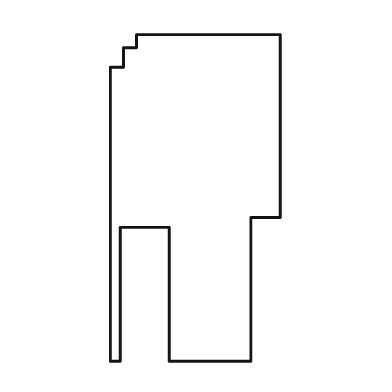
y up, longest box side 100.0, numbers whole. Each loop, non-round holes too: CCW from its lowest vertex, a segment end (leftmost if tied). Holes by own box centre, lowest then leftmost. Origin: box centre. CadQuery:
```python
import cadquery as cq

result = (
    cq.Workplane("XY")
    .moveTo(-26.0, -50.0)
    .lineTo(-23.0, -50.0)
    .lineTo(-23.0, -9.0)
    .lineTo(-8.0, -9.0)
    .lineTo(-8.0, -50.0)
    .lineTo(17.0, -50.0)
    .lineTo(17.0, -6.0)
    .lineTo(26.0, -6.0)
    .lineTo(26.0, 50.0)
    .lineTo(-18.0, 50.0)
    .lineTo(-18.0, 46.0)
    .lineTo(-22.0, 46.0)
    .lineTo(-22.0, 40.0)
    .lineTo(-26.0, 40.0)
    .close()
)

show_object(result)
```